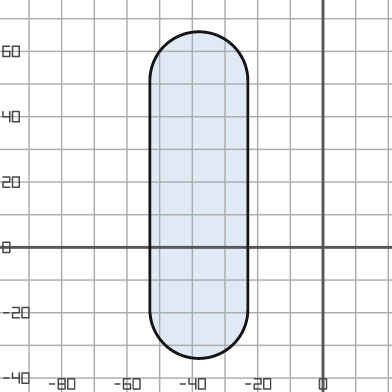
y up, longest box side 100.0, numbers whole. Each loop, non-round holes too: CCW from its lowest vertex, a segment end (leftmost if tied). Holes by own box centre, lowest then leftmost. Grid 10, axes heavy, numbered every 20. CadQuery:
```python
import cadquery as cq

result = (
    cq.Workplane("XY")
    .moveTo(-53.0, -19.0)
    .threePointArc((-38.0, -34.0), (-23.0, -19.0))
    .lineTo(-23.0, 51.0)
    .threePointArc((-38.0, 66.0), (-53.0, 51.0))
    .close()
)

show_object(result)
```